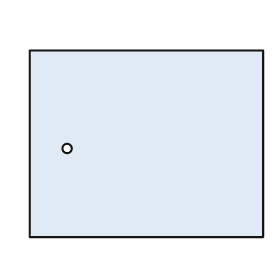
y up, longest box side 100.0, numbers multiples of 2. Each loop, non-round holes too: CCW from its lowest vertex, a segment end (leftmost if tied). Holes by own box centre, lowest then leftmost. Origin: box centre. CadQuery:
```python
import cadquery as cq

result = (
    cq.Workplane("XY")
    .moveTo(-50.0, -40.0)
    .lineTo(50.0, -40.0)
    .lineTo(50.0, 40.0)
    .lineTo(-50.0, 40.0)
    .close()
    .moveTo(-34.0, -2.0)
    .circle(2.0)
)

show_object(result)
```